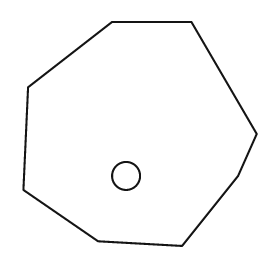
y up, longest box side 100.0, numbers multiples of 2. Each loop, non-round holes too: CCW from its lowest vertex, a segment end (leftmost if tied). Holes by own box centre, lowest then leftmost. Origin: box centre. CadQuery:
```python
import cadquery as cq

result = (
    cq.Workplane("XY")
    .moveTo(18.0, -48.0)
    .lineTo(42.0, -18.0)
    .lineTo(50.0, 0.0)
    .lineTo(22.0, 48.0)
    .lineTo(-12.0, 48.0)
    .lineTo(-48.0, 20.0)
    .lineTo(-50.0, -24.0)
    .lineTo(-18.0, -46.0)
    .close()
    .moveTo(-6.0, -18.0)
    .circle(6.0)
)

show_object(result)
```